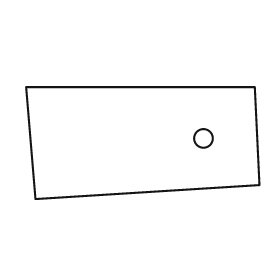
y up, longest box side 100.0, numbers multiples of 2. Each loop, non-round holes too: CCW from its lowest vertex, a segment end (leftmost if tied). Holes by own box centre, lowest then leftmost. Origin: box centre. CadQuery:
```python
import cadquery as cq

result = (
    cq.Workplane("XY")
    .moveTo(-46.0, -24.0)
    .lineTo(50.0, -18.0)
    .lineTo(48.0, 24.0)
    .lineTo(-50.0, 24.0)
    .close()
    .moveTo(26.0, 2.0)
    .circle(4.0)
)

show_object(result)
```